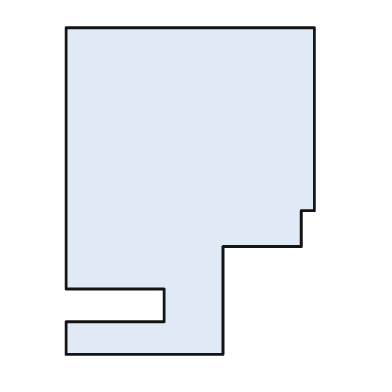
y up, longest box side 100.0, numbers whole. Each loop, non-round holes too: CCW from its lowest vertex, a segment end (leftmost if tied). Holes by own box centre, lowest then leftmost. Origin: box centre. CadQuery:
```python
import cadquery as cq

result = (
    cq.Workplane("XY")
    .moveTo(-38.0, -50.0)
    .lineTo(10.0, -50.0)
    .lineTo(10.0, -17.0)
    .lineTo(34.0, -17.0)
    .lineTo(34.0, -6.0)
    .lineTo(38.0, -6.0)
    .lineTo(38.0, 50.0)
    .lineTo(-38.0, 50.0)
    .lineTo(-38.0, -30.0)
    .lineTo(-8.0, -30.0)
    .lineTo(-8.0, -40.0)
    .lineTo(-38.0, -40.0)
    .close()
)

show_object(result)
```